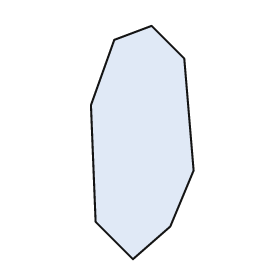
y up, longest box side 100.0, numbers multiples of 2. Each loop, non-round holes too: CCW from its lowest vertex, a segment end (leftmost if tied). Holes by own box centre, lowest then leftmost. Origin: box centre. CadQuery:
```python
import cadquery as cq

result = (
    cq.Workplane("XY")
    .moveTo(-4.0, -50.0)
    .lineTo(12.0, -36.0)
    .lineTo(22.0, -12.0)
    .lineTo(18.0, 36.0)
    .lineTo(4.0, 50.0)
    .lineTo(-12.0, 44.0)
    .lineTo(-22.0, 16.0)
    .lineTo(-20.0, -34.0)
    .close()
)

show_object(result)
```